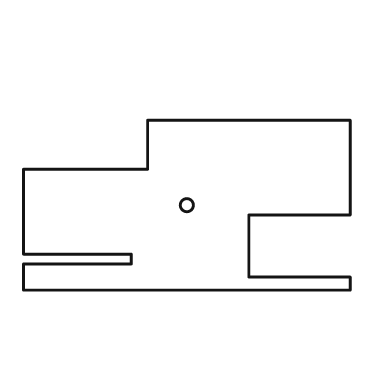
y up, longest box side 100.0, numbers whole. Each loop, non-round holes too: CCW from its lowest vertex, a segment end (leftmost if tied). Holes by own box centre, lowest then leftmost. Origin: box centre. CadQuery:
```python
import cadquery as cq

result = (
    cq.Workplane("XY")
    .moveTo(-50.0, -26.0)
    .lineTo(50.0, -26.0)
    .lineTo(50.0, -22.0)
    .lineTo(19.0, -22.0)
    .lineTo(19.0, -3.0)
    .lineTo(50.0, -3.0)
    .lineTo(50.0, 26.0)
    .lineTo(-12.0, 26.0)
    .lineTo(-12.0, 11.0)
    .lineTo(-50.0, 11.0)
    .lineTo(-50.0, -15.0)
    .lineTo(-17.0, -15.0)
    .lineTo(-17.0, -18.0)
    .lineTo(-50.0, -18.0)
    .close()
    .moveTo(0.0, 0.0)
    .circle(2.0)
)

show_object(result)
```